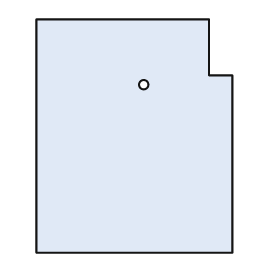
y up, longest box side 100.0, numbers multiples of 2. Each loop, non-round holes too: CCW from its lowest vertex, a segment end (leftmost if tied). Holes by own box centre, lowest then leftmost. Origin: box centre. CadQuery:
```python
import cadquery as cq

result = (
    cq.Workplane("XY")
    .moveTo(-42.0, -50.0)
    .lineTo(42.0, -50.0)
    .lineTo(42.0, 26.0)
    .lineTo(32.0, 26.0)
    .lineTo(32.0, 50.0)
    .lineTo(-42.0, 50.0)
    .close()
    .moveTo(4.0, 22.0)
    .circle(2.0)
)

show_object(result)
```